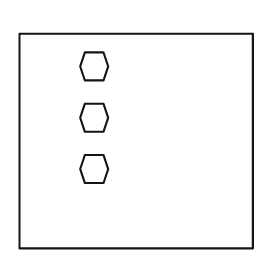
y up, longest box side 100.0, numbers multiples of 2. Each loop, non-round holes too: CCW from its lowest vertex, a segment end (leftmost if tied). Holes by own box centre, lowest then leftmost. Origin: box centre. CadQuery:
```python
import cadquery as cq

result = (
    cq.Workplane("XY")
    .moveTo(-50.0, -46.0)
    .lineTo(50.0, -46.0)
    .lineTo(50.0, 46.0)
    .lineTo(-50.0, 46.0)
    .close()
    .moveTo(-22.0, -18.0)
    .lineTo(-14.0, -18.0)
    .lineTo(-12.0, -12.0)
    .lineTo(-14.0, -6.0)
    .lineTo(-22.0, -6.0)
    .lineTo(-24.0, -12.0)
    .close()
    .moveTo(-22.0, 4.0)
    .lineTo(-14.0, 4.0)
    .lineTo(-12.0, 10.0)
    .lineTo(-14.0, 16.0)
    .lineTo(-22.0, 16.0)
    .lineTo(-24.0, 10.0)
    .close()
    .moveTo(-22.0, 26.0)
    .lineTo(-14.0, 26.0)
    .lineTo(-12.0, 32.0)
    .lineTo(-14.0, 38.0)
    .lineTo(-22.0, 38.0)
    .lineTo(-24.0, 32.0)
    .close()
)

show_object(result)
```